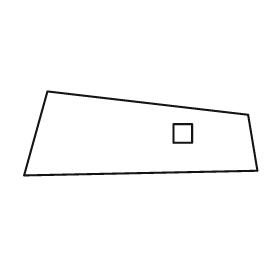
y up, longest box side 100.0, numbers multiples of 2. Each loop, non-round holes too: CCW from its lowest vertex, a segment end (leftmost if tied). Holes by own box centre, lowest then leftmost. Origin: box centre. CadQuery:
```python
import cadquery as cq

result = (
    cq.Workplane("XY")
    .moveTo(-50.0, -18.0)
    .lineTo(50.0, -16.0)
    .lineTo(46.0, 8.0)
    .lineTo(-40.0, 18.0)
    .close()
    .moveTo(14.0, -4.0)
    .lineTo(22.0, -4.0)
    .lineTo(22.0, 4.0)
    .lineTo(14.0, 4.0)
    .close()
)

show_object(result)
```